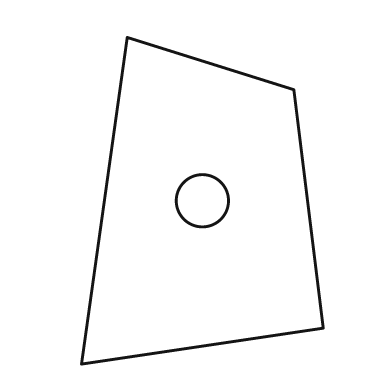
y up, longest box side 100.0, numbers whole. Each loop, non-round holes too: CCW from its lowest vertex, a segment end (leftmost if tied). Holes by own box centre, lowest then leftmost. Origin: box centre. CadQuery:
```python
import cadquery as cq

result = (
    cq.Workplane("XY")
    .moveTo(-37.0, -50.0)
    .lineTo(37.0, -39.0)
    .lineTo(28.0, 34.0)
    .lineTo(-23.0, 50.0)
    .close()
    .moveTo(0.0, 0.0)
    .circle(8.0)
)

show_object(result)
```